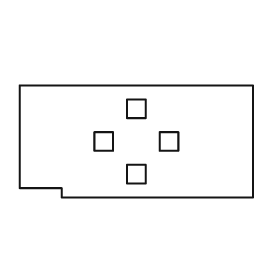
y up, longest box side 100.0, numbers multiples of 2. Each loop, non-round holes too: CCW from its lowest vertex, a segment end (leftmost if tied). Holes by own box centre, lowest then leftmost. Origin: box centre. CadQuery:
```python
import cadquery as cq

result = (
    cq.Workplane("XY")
    .moveTo(-32.0, -24.0)
    .lineTo(50.0, -24.0)
    .lineTo(50.0, 24.0)
    .lineTo(-50.0, 24.0)
    .lineTo(-50.0, -20.0)
    .lineTo(-32.0, -20.0)
    .close()
    .moveTo(-4.0, -18.0)
    .lineTo(4.0, -18.0)
    .lineTo(4.0, -10.0)
    .lineTo(-4.0, -10.0)
    .close()
    .moveTo(-18.0, -4.0)
    .lineTo(-10.0, -4.0)
    .lineTo(-10.0, 4.0)
    .lineTo(-18.0, 4.0)
    .close()
    .moveTo(10.0, -4.0)
    .lineTo(18.0, -4.0)
    .lineTo(18.0, 4.0)
    .lineTo(10.0, 4.0)
    .close()
    .moveTo(-4.0, 10.0)
    .lineTo(4.0, 10.0)
    .lineTo(4.0, 18.0)
    .lineTo(-4.0, 18.0)
    .close()
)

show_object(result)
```